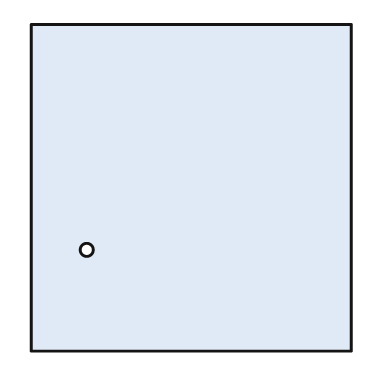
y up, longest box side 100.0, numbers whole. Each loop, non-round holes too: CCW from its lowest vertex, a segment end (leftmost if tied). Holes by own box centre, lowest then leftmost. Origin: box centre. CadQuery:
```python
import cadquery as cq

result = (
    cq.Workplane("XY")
    .moveTo(-49.0, -50.0)
    .lineTo(49.0, -50.0)
    .lineTo(49.0, 50.0)
    .lineTo(-49.0, 50.0)
    .close()
    .moveTo(-32.0, -19.0)
    .circle(2.0)
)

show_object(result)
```